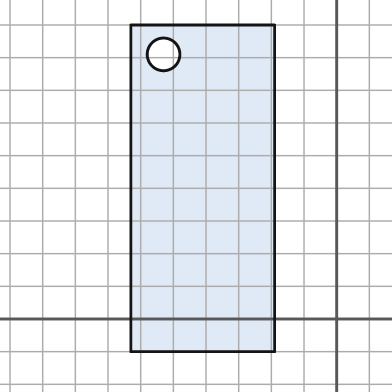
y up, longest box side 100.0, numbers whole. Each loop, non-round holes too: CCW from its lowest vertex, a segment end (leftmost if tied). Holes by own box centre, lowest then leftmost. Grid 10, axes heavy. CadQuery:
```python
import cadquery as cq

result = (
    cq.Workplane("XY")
    .moveTo(-63.0, -10.0)
    .lineTo(-19.0, -10.0)
    .lineTo(-19.0, 90.0)
    .lineTo(-63.0, 90.0)
    .close()
    .moveTo(-53.0, 81.0)
    .circle(5.0)
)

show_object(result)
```